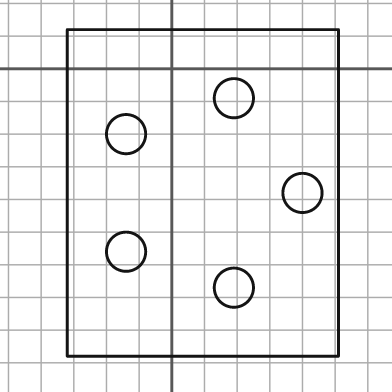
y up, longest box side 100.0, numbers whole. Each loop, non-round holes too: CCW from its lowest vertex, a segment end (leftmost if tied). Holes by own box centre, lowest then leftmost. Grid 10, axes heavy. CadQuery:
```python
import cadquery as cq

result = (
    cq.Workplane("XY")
    .moveTo(-32.0, -88.0)
    .lineTo(51.0, -88.0)
    .lineTo(51.0, 12.0)
    .lineTo(-32.0, 12.0)
    .close()
    .moveTo(19.0, -67.0)
    .circle(6.0)
    .moveTo(-14.0, -56.0)
    .circle(6.0)
    .moveTo(40.0, -38.0)
    .circle(6.0)
    .moveTo(-14.0, -20.0)
    .circle(6.0)
    .moveTo(19.0, -9.0)
    .circle(6.0)
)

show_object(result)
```